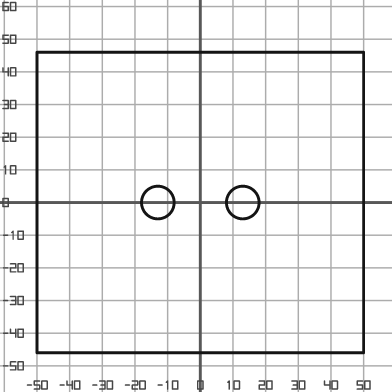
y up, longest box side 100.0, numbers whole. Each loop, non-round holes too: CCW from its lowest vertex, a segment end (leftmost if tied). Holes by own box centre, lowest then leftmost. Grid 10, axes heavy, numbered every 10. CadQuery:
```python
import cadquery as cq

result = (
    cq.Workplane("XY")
    .moveTo(-50.0, -46.0)
    .lineTo(50.0, -46.0)
    .lineTo(50.0, 46.0)
    .lineTo(-50.0, 46.0)
    .close()
    .moveTo(-13.0, 0.0)
    .circle(5.0)
    .moveTo(13.0, 0.0)
    .circle(5.0)
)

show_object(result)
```